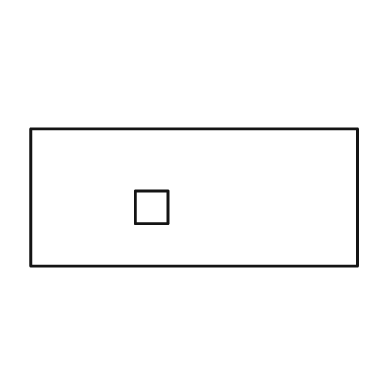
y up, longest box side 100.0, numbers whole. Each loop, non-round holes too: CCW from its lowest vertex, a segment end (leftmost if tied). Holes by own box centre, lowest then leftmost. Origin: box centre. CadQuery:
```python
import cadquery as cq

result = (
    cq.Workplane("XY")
    .moveTo(-50.0, -21.0)
    .lineTo(50.0, -21.0)
    .lineTo(50.0, 21.0)
    .lineTo(-50.0, 21.0)
    .close()
    .moveTo(-18.0, -8.0)
    .lineTo(-8.0, -8.0)
    .lineTo(-8.0, 2.0)
    .lineTo(-18.0, 2.0)
    .close()
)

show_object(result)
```